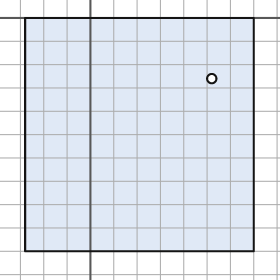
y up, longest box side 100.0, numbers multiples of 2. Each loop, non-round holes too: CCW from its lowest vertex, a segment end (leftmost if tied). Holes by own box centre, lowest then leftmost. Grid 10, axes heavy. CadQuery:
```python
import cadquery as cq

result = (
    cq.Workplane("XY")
    .moveTo(-28.0, -100.0)
    .lineTo(70.0, -100.0)
    .lineTo(70.0, 0.0)
    .lineTo(-28.0, 0.0)
    .close()
    .moveTo(52.0, -26.0)
    .circle(2.0)
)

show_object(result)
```